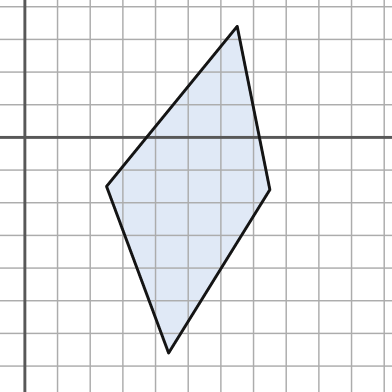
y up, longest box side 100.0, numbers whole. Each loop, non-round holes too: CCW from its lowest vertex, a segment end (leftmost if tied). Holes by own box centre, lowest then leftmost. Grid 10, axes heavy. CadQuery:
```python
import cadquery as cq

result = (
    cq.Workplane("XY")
    .moveTo(44.0, -66.0)
    .lineTo(75.0, -16.0)
    .lineTo(65.0, 34.0)
    .lineTo(25.0, -15.0)
    .close()
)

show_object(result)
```